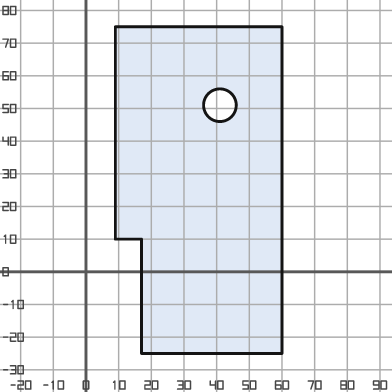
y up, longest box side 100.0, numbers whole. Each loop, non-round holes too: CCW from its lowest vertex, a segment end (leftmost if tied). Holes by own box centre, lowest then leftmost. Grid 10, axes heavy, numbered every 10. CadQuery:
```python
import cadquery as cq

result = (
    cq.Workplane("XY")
    .moveTo(17.0, -25.0)
    .lineTo(60.0, -25.0)
    .lineTo(60.0, 75.0)
    .lineTo(9.0, 75.0)
    .lineTo(9.0, 10.0)
    .lineTo(17.0, 10.0)
    .close()
    .moveTo(41.0, 51.0)
    .circle(5.0)
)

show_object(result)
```